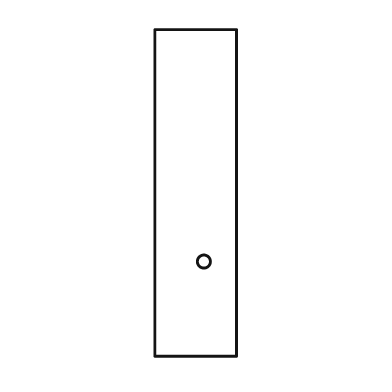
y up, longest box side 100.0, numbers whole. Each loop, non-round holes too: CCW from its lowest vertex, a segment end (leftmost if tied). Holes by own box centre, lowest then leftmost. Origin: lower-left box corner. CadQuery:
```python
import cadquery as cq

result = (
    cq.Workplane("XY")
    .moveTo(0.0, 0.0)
    .lineTo(25.0, 0.0)
    .lineTo(25.0, 100.0)
    .lineTo(0.0, 100.0)
    .close()
    .moveTo(15.0, 29.0)
    .circle(2.0)
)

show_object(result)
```